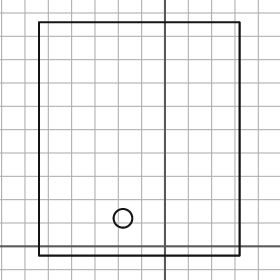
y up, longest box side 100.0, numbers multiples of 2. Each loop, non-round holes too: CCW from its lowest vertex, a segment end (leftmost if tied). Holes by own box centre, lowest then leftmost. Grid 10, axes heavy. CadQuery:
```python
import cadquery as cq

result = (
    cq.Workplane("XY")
    .moveTo(-54.0, -4.0)
    .lineTo(32.0, -4.0)
    .lineTo(32.0, 96.0)
    .lineTo(-54.0, 96.0)
    .close()
    .moveTo(-18.0, 12.0)
    .circle(4.0)
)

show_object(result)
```